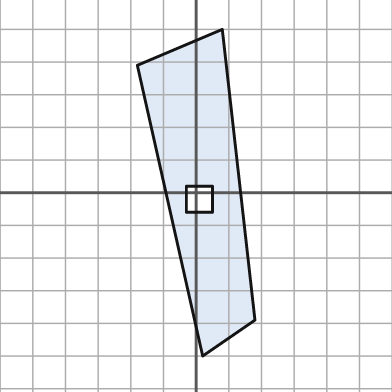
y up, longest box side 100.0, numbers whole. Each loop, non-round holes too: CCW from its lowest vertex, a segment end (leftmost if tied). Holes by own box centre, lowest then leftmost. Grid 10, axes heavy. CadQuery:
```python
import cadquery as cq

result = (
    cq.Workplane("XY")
    .moveTo(2.0, -50.0)
    .lineTo(18.0, -39.0)
    .lineTo(8.0, 50.0)
    .lineTo(-18.0, 39.0)
    .close()
    .moveTo(-3.0, -6.0)
    .lineTo(5.0, -6.0)
    .lineTo(5.0, 2.0)
    .lineTo(-3.0, 2.0)
    .close()
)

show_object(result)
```